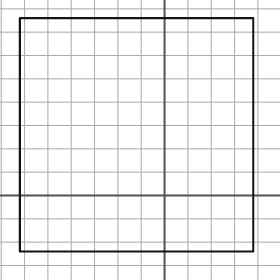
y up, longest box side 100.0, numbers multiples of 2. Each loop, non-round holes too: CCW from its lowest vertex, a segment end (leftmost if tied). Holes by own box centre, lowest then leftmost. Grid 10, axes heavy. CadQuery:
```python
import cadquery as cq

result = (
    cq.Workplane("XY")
    .moveTo(-62.0, -24.0)
    .lineTo(38.0, -24.0)
    .lineTo(38.0, 76.0)
    .lineTo(-62.0, 76.0)
    .close()
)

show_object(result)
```